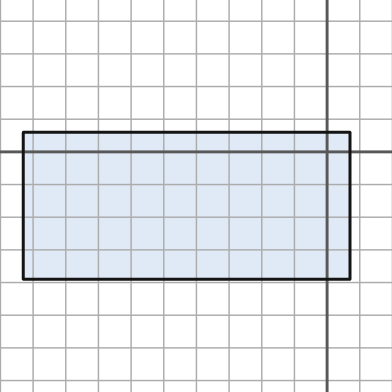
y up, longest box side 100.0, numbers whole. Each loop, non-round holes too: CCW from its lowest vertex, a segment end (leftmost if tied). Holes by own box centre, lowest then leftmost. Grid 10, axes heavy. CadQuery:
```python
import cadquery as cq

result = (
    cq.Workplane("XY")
    .moveTo(-93.0, -39.0)
    .lineTo(7.0, -39.0)
    .lineTo(7.0, 6.0)
    .lineTo(-93.0, 6.0)
    .close()
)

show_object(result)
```